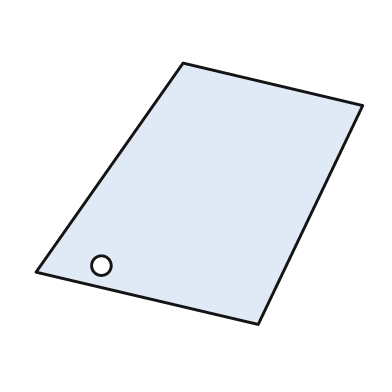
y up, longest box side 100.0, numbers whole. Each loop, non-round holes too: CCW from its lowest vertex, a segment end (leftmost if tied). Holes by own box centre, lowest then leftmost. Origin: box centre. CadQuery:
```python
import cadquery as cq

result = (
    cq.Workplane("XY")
    .moveTo(18.0, -40.0)
    .lineTo(50.0, 27.0)
    .lineTo(-5.0, 40.0)
    .lineTo(-50.0, -24.0)
    .close()
    .moveTo(-30.0, -22.0)
    .circle(3.0)
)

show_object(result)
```